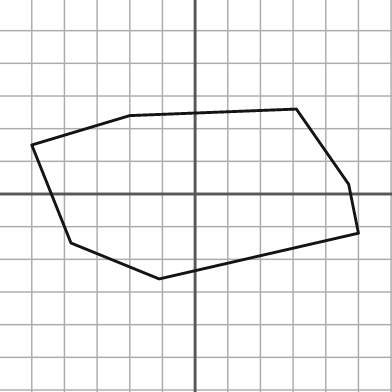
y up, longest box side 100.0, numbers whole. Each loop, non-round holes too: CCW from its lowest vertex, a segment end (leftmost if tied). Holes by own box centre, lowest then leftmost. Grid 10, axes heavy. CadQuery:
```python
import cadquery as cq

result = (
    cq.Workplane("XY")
    .moveTo(-11.0, -26.0)
    .lineTo(50.0, -12.0)
    .lineTo(47.0, 3.0)
    .lineTo(31.0, 26.0)
    .lineTo(-20.0, 24.0)
    .lineTo(-50.0, 15.0)
    .lineTo(-38.0, -15.0)
    .close()
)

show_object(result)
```